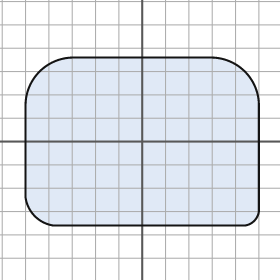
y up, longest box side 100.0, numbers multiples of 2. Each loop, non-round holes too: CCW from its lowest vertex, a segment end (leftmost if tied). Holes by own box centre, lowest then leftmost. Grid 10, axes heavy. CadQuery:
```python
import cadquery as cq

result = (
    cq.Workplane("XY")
    .moveTo(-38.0, -36.0)
    .lineTo(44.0, -36.0)
    .threePointArc((48.0, -34.0), (50.0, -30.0))
    .lineTo(50.0, 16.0)
    .threePointArc((44.0, 30.0), (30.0, 36.0))
    .lineTo(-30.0, 36.0)
    .threePointArc((-44.0, 30.0), (-50.0, 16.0))
    .lineTo(-50.0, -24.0)
    .threePointArc((-46.0, -32.0), (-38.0, -36.0))
    .close()
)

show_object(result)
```